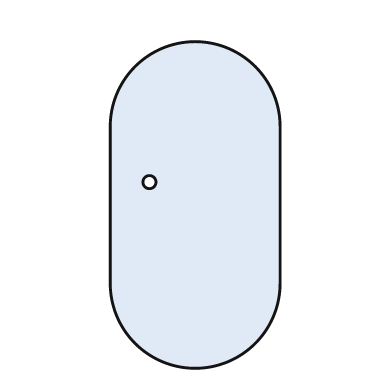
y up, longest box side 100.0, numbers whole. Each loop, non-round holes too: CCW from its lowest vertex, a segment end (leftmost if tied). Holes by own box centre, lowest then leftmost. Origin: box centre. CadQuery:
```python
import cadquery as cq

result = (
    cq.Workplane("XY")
    .moveTo(-26.0, -24.0)
    .threePointArc((0.0, -50.0), (26.0, -24.0))
    .lineTo(26.0, 24.0)
    .threePointArc((0.0, 50.0), (-26.0, 24.0))
    .close()
    .moveTo(-14.0, 7.0)
    .circle(2.0)
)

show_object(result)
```